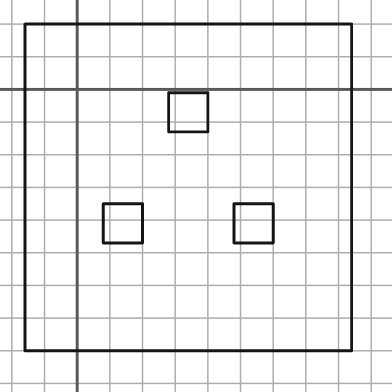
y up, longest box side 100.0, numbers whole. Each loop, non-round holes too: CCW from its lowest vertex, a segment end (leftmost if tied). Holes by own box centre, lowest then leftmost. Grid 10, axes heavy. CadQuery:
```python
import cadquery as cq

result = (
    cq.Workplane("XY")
    .moveTo(-16.0, -80.0)
    .lineTo(84.0, -80.0)
    .lineTo(84.0, 20.0)
    .lineTo(-16.0, 20.0)
    .close()
    .moveTo(8.0, -47.0)
    .lineTo(20.0, -47.0)
    .lineTo(20.0, -35.0)
    .lineTo(8.0, -35.0)
    .close()
    .moveTo(48.0, -47.0)
    .lineTo(60.0, -47.0)
    .lineTo(60.0, -35.0)
    .lineTo(48.0, -35.0)
    .close()
    .moveTo(28.0, -13.0)
    .lineTo(40.0, -13.0)
    .lineTo(40.0, -1.0)
    .lineTo(28.0, -1.0)
    .close()
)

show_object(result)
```